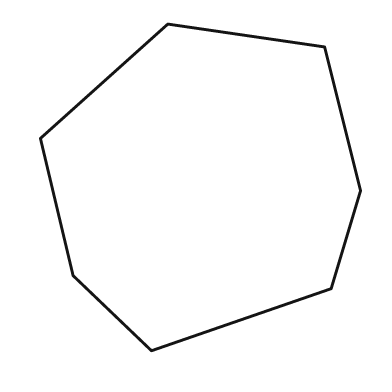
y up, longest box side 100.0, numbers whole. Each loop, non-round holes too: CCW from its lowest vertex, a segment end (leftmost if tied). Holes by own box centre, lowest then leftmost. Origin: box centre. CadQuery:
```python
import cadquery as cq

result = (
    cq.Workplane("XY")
    .moveTo(-15.0, -50.0)
    .lineTo(40.0, -31.0)
    .lineTo(49.0, -1.0)
    .lineTo(38.0, 43.0)
    .lineTo(-10.0, 50.0)
    .lineTo(-49.0, 15.0)
    .lineTo(-39.0, -27.0)
    .close()
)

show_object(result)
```